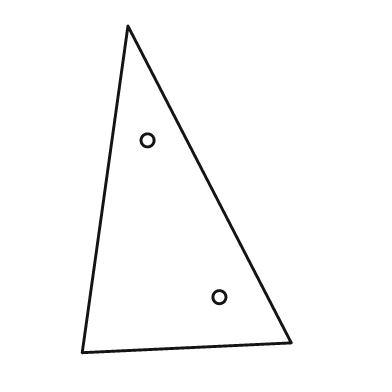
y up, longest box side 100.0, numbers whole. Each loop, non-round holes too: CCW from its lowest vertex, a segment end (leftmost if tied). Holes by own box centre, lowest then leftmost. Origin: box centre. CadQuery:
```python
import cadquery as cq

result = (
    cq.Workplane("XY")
    .moveTo(-32.0, -50.0)
    .lineTo(32.0, -47.0)
    .lineTo(-18.0, 50.0)
    .close()
    .moveTo(10.0, -33.0)
    .circle(2.0)
    .moveTo(-12.0, 15.0)
    .circle(2.0)
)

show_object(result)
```